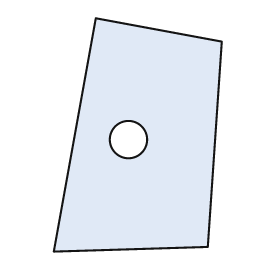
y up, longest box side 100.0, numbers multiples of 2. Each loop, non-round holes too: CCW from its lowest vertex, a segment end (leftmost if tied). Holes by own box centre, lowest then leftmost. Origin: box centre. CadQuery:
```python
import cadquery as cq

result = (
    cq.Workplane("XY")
    .moveTo(-36.0, -50.0)
    .lineTo(30.0, -48.0)
    .lineTo(36.0, 40.0)
    .lineTo(-18.0, 50.0)
    .close()
    .moveTo(-4.0, -2.0)
    .circle(8.0)
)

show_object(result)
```